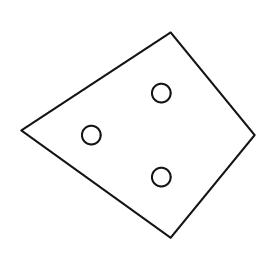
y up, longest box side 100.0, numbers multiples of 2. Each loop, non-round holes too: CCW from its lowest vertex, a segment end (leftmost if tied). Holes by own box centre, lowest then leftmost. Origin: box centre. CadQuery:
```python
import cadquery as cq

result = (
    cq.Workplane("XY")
    .moveTo(14.0, -44.0)
    .lineTo(50.0, 0.0)
    .lineTo(14.0, 44.0)
    .lineTo(-50.0, 2.0)
    .close()
    .moveTo(10.0, -18.0)
    .circle(4.0)
    .moveTo(-20.0, 0.0)
    .circle(4.0)
    .moveTo(10.0, 18.0)
    .circle(4.0)
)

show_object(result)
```